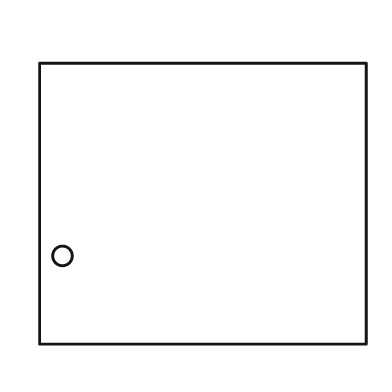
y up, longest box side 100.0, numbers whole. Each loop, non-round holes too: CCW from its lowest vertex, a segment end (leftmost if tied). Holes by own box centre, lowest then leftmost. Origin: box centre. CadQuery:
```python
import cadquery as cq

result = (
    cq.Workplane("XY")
    .moveTo(-50.0, -43.0)
    .lineTo(50.0, -43.0)
    .lineTo(50.0, 43.0)
    .lineTo(-50.0, 43.0)
    .close()
    .moveTo(-43.0, -16.0)
    .circle(3.0)
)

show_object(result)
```